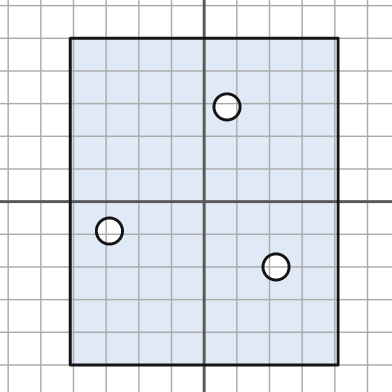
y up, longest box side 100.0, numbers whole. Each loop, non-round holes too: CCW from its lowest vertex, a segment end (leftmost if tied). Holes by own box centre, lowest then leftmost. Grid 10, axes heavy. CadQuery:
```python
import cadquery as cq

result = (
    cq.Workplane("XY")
    .moveTo(-41.0, -50.0)
    .lineTo(41.0, -50.0)
    .lineTo(41.0, 50.0)
    .lineTo(-41.0, 50.0)
    .close()
    .moveTo(22.0, -20.0)
    .circle(4.0)
    .moveTo(-29.0, -9.0)
    .circle(4.0)
    .moveTo(7.0, 29.0)
    .circle(4.0)
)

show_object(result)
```